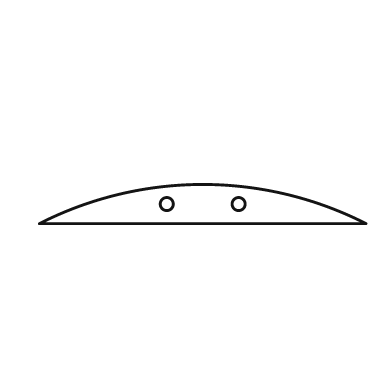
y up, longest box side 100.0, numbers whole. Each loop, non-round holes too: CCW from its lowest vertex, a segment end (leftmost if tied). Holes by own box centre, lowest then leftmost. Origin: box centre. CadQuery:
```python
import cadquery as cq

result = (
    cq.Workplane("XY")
    .moveTo(-50.0, -6.0)
    .lineTo(50.0, -6.0)
    .threePointArc((0.0, 6.0), (-50.0, -6.0))
    .close()
    .moveTo(-11.0, 0.0)
    .circle(2.0)
    .moveTo(11.0, 0.0)
    .circle(2.0)
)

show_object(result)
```